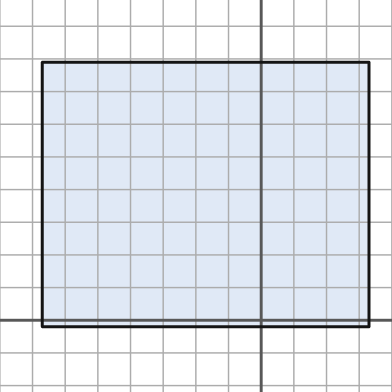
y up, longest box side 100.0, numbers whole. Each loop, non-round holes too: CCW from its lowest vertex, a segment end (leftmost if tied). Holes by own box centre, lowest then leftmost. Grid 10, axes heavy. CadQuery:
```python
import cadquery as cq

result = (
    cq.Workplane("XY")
    .moveTo(-67.0, -2.0)
    .lineTo(33.0, -2.0)
    .lineTo(33.0, 79.0)
    .lineTo(-67.0, 79.0)
    .close()
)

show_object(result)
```